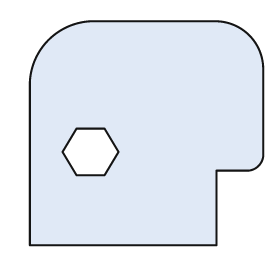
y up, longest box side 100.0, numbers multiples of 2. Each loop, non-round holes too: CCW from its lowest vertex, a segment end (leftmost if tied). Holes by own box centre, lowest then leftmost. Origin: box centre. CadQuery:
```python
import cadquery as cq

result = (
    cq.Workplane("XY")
    .moveTo(-50.0, -48.0)
    .lineTo(30.0, -48.0)
    .lineTo(30.0, -16.0)
    .lineTo(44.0, -16.0)
    .threePointArc((48.0, -14.0), (50.0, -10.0))
    .lineTo(50.0, 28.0)
    .threePointArc((44.0, 42.0), (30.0, 48.0))
    .lineTo(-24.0, 48.0)
    .threePointArc((-42.0, 40.0), (-50.0, 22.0))
    .close()
    .moveTo(-30.0, -18.0)
    .lineTo(-18.0, -18.0)
    .lineTo(-12.0, -8.0)
    .lineTo(-18.0, 2.0)
    .lineTo(-30.0, 2.0)
    .lineTo(-36.0, -8.0)
    .close()
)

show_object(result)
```